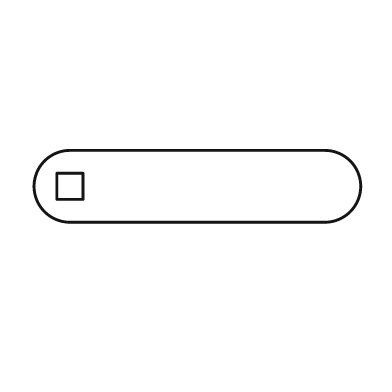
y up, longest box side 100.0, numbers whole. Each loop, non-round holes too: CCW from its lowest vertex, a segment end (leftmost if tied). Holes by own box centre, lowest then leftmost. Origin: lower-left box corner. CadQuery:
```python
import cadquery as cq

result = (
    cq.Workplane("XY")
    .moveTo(11.0, 0.0)
    .lineTo(89.0, 0.0)
    .threePointArc((100.0, 11.0), (89.0, 22.0))
    .lineTo(11.0, 22.0)
    .threePointArc((0.0, 11.0), (11.0, 0.0))
    .close()
    .moveTo(7.0, 7.0)
    .lineTo(15.0, 7.0)
    .lineTo(15.0, 15.0)
    .lineTo(7.0, 15.0)
    .close()
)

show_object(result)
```